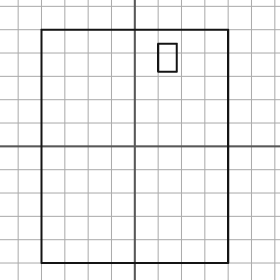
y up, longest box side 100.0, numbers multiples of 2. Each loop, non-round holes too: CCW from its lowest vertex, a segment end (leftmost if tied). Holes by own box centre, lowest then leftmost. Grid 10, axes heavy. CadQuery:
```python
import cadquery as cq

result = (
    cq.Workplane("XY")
    .moveTo(-40.0, -50.0)
    .lineTo(40.0, -50.0)
    .lineTo(40.0, 50.0)
    .lineTo(-40.0, 50.0)
    .close()
    .moveTo(10.0, 32.0)
    .lineTo(18.0, 32.0)
    .lineTo(18.0, 44.0)
    .lineTo(10.0, 44.0)
    .close()
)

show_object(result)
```